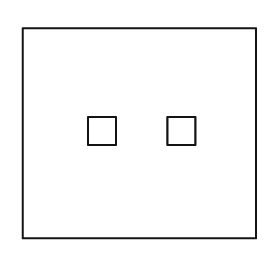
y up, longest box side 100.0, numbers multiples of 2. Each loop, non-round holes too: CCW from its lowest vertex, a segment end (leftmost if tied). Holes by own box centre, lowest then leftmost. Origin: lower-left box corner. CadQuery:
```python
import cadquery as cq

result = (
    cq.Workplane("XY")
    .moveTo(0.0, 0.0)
    .lineTo(100.0, 0.0)
    .lineTo(100.0, 90.0)
    .lineTo(0.0, 90.0)
    .close()
    .moveTo(28.0, 40.0)
    .lineTo(40.0, 40.0)
    .lineTo(40.0, 52.0)
    .lineTo(28.0, 52.0)
    .close()
    .moveTo(62.0, 40.0)
    .lineTo(74.0, 40.0)
    .lineTo(74.0, 52.0)
    .lineTo(62.0, 52.0)
    .close()
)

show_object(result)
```